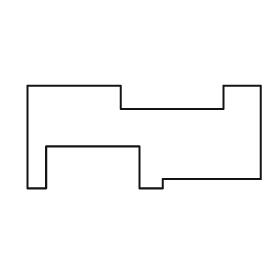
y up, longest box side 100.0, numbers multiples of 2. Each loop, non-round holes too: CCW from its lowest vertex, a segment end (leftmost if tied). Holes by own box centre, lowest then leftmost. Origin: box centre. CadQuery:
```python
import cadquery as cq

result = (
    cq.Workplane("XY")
    .moveTo(-50.0, -22.0)
    .lineTo(-42.0, -22.0)
    .lineTo(-42.0, -4.0)
    .lineTo(-2.0, -4.0)
    .lineTo(-2.0, -22.0)
    .lineTo(8.0, -22.0)
    .lineTo(8.0, -18.0)
    .lineTo(50.0, -18.0)
    .lineTo(50.0, 22.0)
    .lineTo(34.0, 22.0)
    .lineTo(34.0, 12.0)
    .lineTo(-10.0, 12.0)
    .lineTo(-10.0, 22.0)
    .lineTo(-50.0, 22.0)
    .close()
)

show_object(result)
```